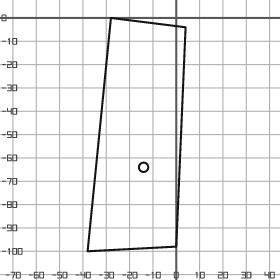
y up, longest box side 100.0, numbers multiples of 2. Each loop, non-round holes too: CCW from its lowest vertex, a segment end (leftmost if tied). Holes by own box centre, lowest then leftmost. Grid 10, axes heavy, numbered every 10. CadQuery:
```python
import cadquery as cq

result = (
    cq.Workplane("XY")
    .moveTo(-38.0, -100.0)
    .lineTo(0.0, -98.0)
    .lineTo(4.0, -4.0)
    .lineTo(-28.0, 0.0)
    .close()
    .moveTo(-14.0, -64.0)
    .circle(2.0)
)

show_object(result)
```